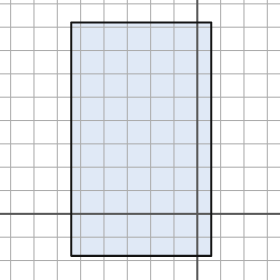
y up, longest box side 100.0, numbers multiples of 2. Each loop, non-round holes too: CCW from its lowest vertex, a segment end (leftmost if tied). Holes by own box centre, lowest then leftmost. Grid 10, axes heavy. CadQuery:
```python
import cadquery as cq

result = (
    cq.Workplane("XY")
    .moveTo(-54.0, -18.0)
    .lineTo(6.0, -18.0)
    .lineTo(6.0, 82.0)
    .lineTo(-54.0, 82.0)
    .close()
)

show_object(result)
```